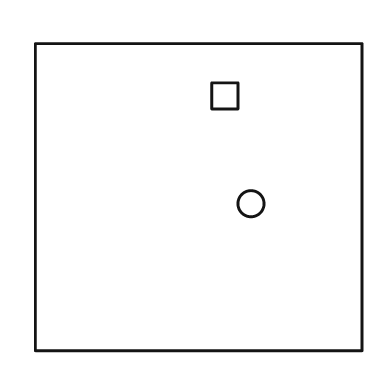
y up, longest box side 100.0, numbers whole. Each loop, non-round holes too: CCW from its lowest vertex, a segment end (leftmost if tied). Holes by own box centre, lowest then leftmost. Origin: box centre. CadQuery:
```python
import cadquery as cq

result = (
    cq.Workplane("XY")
    .moveTo(-50.0, -47.0)
    .lineTo(50.0, -47.0)
    .lineTo(50.0, 47.0)
    .lineTo(-50.0, 47.0)
    .close()
    .moveTo(16.0, -2.0)
    .circle(4.0)
    .moveTo(4.0, 27.0)
    .lineTo(12.0, 27.0)
    .lineTo(12.0, 35.0)
    .lineTo(4.0, 35.0)
    .close()
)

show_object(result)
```